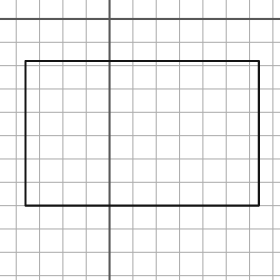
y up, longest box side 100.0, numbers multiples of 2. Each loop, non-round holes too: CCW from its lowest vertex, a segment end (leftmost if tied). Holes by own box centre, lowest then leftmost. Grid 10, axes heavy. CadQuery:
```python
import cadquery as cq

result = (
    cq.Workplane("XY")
    .moveTo(-36.0, -80.0)
    .lineTo(64.0, -80.0)
    .lineTo(64.0, -18.0)
    .lineTo(-36.0, -18.0)
    .close()
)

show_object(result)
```